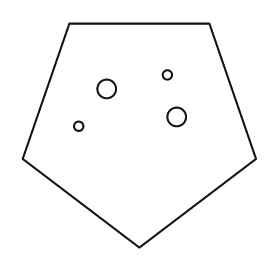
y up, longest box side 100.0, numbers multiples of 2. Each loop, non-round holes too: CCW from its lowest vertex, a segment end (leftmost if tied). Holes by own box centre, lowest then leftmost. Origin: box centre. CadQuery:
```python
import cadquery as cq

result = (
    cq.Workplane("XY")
    .moveTo(0.0, -48.0)
    .lineTo(50.0, -10.0)
    .lineTo(30.0, 48.0)
    .lineTo(-30.0, 48.0)
    .lineTo(-50.0, -10.0)
    .close()
    .moveTo(-26.0, 4.0)
    .circle(2.0)
    .moveTo(16.0, 8.0)
    .circle(4.0)
    .moveTo(-14.0, 20.0)
    .circle(4.0)
    .moveTo(12.0, 26.0)
    .circle(2.0)
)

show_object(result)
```